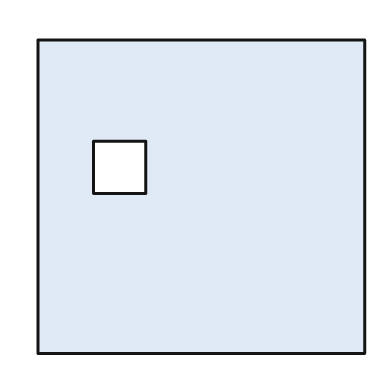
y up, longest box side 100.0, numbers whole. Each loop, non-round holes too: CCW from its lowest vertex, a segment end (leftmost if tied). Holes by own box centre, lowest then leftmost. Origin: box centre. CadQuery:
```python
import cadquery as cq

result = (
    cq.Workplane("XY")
    .moveTo(-50.0, -48.0)
    .lineTo(50.0, -48.0)
    .lineTo(50.0, 48.0)
    .lineTo(-50.0, 48.0)
    .close()
    .moveTo(-33.0, 1.0)
    .lineTo(-17.0, 1.0)
    .lineTo(-17.0, 17.0)
    .lineTo(-33.0, 17.0)
    .close()
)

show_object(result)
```